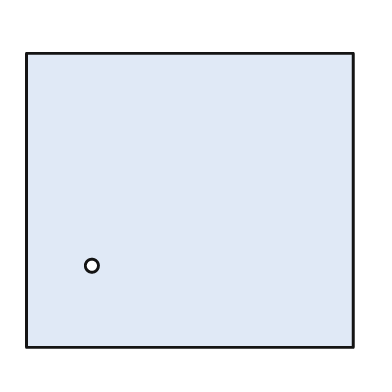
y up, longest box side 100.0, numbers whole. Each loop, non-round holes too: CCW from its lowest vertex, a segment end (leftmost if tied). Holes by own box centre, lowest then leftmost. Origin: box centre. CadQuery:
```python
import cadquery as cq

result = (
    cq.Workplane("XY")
    .moveTo(-50.0, -45.0)
    .lineTo(50.0, -45.0)
    .lineTo(50.0, 45.0)
    .lineTo(-50.0, 45.0)
    .close()
    .moveTo(-30.0, -20.0)
    .circle(2.0)
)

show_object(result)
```